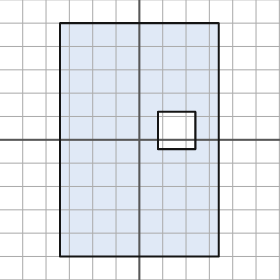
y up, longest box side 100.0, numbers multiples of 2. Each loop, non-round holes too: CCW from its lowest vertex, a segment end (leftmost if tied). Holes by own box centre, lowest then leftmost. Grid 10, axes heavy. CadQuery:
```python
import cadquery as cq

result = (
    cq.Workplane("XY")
    .moveTo(-34.0, -50.0)
    .lineTo(34.0, -50.0)
    .lineTo(34.0, 50.0)
    .lineTo(-34.0, 50.0)
    .close()
    .moveTo(8.0, -4.0)
    .lineTo(24.0, -4.0)
    .lineTo(24.0, 12.0)
    .lineTo(8.0, 12.0)
    .close()
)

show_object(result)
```